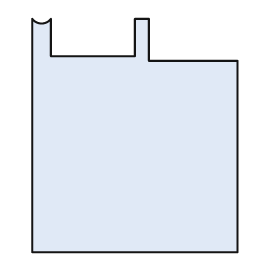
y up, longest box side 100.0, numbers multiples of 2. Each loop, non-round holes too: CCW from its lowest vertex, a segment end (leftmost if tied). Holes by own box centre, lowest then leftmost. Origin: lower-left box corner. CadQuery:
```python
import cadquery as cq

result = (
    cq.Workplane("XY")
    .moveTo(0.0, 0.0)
    .lineTo(88.0, 0.0)
    .lineTo(88.0, 82.0)
    .lineTo(50.0, 82.0)
    .lineTo(50.0, 100.0)
    .lineTo(44.0, 100.0)
    .lineTo(44.0, 84.0)
    .lineTo(8.0, 84.0)
    .lineTo(8.0, 100.0)
    .threePointArc((4.0, 98.0), (0.0, 100.0))
    .close()
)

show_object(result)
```